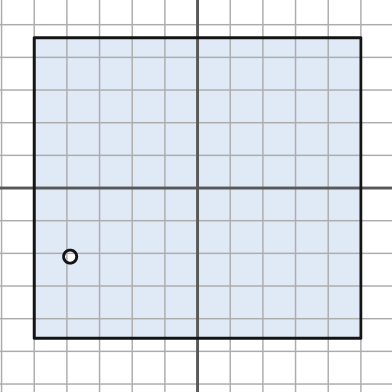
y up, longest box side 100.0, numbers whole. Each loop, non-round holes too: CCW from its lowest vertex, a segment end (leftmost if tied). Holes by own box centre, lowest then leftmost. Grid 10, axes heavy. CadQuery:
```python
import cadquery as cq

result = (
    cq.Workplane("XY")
    .moveTo(-50.0, -46.0)
    .lineTo(50.0, -46.0)
    .lineTo(50.0, 46.0)
    .lineTo(-50.0, 46.0)
    .close()
    .moveTo(-39.0, -21.0)
    .circle(2.0)
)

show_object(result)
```